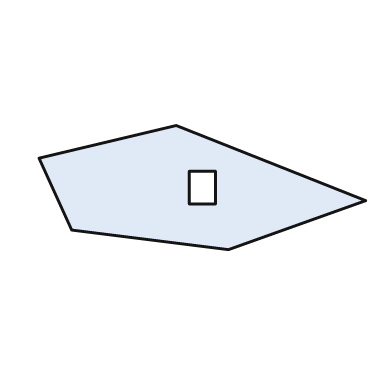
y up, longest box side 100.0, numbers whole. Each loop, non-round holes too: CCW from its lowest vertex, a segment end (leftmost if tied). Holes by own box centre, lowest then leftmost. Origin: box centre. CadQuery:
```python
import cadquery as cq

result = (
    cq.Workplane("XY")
    .moveTo(8.0, -19.0)
    .lineTo(50.0, -4.0)
    .lineTo(-8.0, 19.0)
    .lineTo(-50.0, 9.0)
    .lineTo(-40.0, -13.0)
    .close()
    .moveTo(-4.0, -5.0)
    .lineTo(4.0, -5.0)
    .lineTo(4.0, 5.0)
    .lineTo(-4.0, 5.0)
    .close()
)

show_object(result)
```